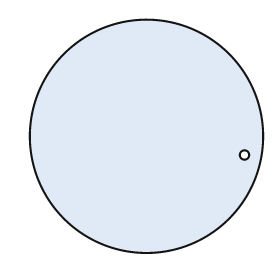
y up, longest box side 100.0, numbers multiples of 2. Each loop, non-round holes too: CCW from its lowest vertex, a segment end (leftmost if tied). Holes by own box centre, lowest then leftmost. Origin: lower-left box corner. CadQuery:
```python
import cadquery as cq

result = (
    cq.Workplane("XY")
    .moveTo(50.0, 50.0)
    .circle(50.0)
    .moveTo(92.0, 42.0)
    .circle(2.0)
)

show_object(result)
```